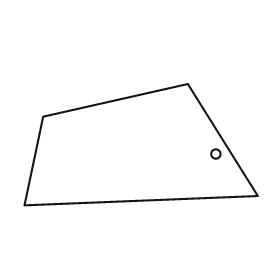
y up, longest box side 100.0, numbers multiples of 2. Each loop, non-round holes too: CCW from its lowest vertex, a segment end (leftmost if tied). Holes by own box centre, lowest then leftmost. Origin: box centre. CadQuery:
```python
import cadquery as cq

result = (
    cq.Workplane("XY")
    .moveTo(-50.0, -26.0)
    .lineTo(50.0, -22.0)
    .lineTo(20.0, 26.0)
    .lineTo(-42.0, 12.0)
    .close()
    .moveTo(32.0, -4.0)
    .circle(2.0)
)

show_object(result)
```